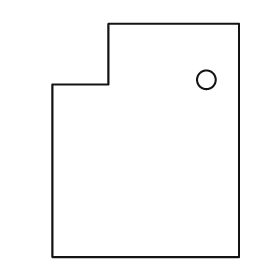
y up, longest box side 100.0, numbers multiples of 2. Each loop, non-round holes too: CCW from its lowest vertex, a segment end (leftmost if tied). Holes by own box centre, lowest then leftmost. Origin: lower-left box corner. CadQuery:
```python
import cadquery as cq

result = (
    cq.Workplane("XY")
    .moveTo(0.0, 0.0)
    .lineTo(80.0, 0.0)
    .lineTo(80.0, 100.0)
    .lineTo(24.0, 100.0)
    .lineTo(24.0, 74.0)
    .lineTo(0.0, 74.0)
    .close()
    .moveTo(66.0, 76.0)
    .circle(4.0)
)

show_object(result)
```